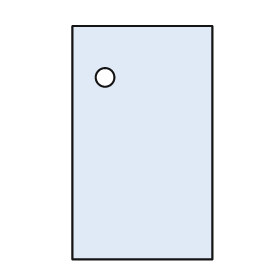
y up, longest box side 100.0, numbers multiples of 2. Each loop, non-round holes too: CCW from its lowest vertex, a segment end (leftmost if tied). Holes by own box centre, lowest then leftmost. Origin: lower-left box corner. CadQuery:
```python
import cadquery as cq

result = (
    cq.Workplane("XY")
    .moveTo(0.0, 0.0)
    .lineTo(60.0, 0.0)
    .lineTo(60.0, 100.0)
    .lineTo(0.0, 100.0)
    .close()
    .moveTo(14.0, 78.0)
    .circle(4.0)
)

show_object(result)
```